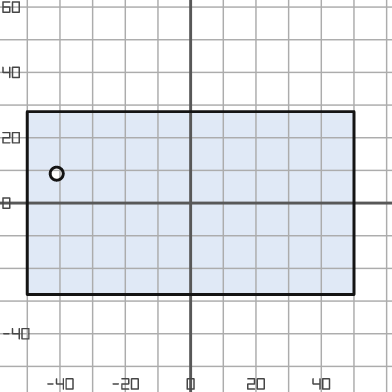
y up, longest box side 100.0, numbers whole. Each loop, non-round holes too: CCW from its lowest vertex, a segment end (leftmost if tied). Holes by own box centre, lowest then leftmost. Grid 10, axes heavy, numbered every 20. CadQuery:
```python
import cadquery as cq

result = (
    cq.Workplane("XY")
    .moveTo(-50.0, -28.0)
    .lineTo(50.0, -28.0)
    .lineTo(50.0, 28.0)
    .lineTo(-50.0, 28.0)
    .close()
    .moveTo(-41.0, 9.0)
    .circle(2.0)
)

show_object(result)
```